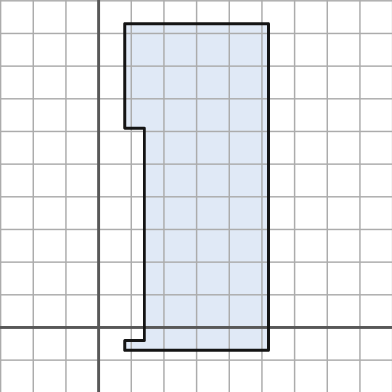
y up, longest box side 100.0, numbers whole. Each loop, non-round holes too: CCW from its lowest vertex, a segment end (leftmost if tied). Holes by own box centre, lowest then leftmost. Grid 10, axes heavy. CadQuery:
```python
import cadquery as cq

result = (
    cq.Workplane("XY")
    .moveTo(8.0, -7.0)
    .lineTo(52.0, -7.0)
    .lineTo(52.0, 93.0)
    .lineTo(8.0, 93.0)
    .lineTo(8.0, 61.0)
    .lineTo(14.0, 61.0)
    .lineTo(14.0, -4.0)
    .lineTo(8.0, -4.0)
    .close()
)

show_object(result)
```